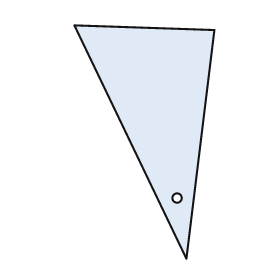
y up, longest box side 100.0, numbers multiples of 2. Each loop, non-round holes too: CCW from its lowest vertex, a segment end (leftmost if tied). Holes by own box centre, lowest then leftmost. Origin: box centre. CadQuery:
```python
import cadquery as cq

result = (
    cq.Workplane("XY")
    .moveTo(18.0, -50.0)
    .lineTo(30.0, 48.0)
    .lineTo(-30.0, 50.0)
    .close()
    .moveTo(14.0, -24.0)
    .circle(2.0)
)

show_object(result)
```